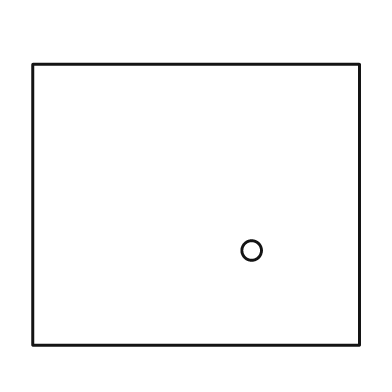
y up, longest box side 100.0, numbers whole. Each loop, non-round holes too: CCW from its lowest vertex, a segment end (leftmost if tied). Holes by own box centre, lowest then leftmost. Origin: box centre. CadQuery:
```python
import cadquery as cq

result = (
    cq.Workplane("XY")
    .moveTo(-50.0, -43.0)
    .lineTo(50.0, -43.0)
    .lineTo(50.0, 43.0)
    .lineTo(-50.0, 43.0)
    .close()
    .moveTo(17.0, -14.0)
    .circle(3.0)
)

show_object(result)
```